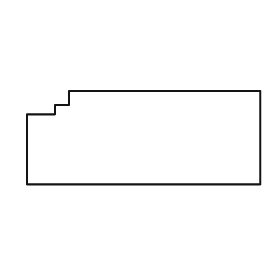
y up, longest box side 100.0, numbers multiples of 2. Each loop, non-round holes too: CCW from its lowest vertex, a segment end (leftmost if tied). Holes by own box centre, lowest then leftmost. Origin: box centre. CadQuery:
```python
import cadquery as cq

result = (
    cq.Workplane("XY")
    .moveTo(-50.0, -20.0)
    .lineTo(50.0, -20.0)
    .lineTo(50.0, 20.0)
    .lineTo(-32.0, 20.0)
    .lineTo(-32.0, 14.0)
    .lineTo(-38.0, 14.0)
    .lineTo(-38.0, 10.0)
    .lineTo(-50.0, 10.0)
    .close()
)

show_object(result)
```